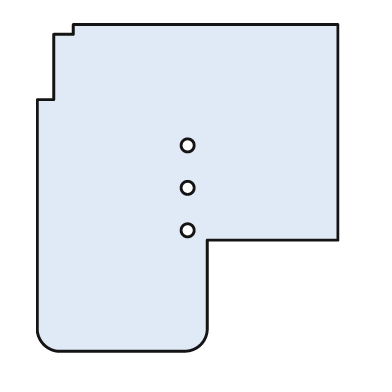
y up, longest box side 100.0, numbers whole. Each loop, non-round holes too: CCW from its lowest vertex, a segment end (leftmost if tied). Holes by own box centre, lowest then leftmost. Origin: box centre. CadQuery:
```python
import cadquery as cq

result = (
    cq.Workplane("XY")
    .moveTo(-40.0, -50.0)
    .lineTo(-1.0, -50.0)
    .threePointArc((4.0, -48.0), (6.0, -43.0))
    .lineTo(6.0, -16.0)
    .lineTo(46.0, -16.0)
    .lineTo(46.0, 50.0)
    .lineTo(-35.0, 50.0)
    .lineTo(-35.0, 47.0)
    .lineTo(-41.0, 47.0)
    .lineTo(-41.0, 27.0)
    .lineTo(-46.0, 27.0)
    .lineTo(-46.0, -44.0)
    .threePointArc((-44.0, -48.0), (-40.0, -50.0))
    .close()
    .moveTo(0.0, -13.0)
    .circle(2.0)
    .moveTo(0.0, 0.0)
    .circle(2.0)
    .moveTo(0.0, 13.0)
    .circle(2.0)
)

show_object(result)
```